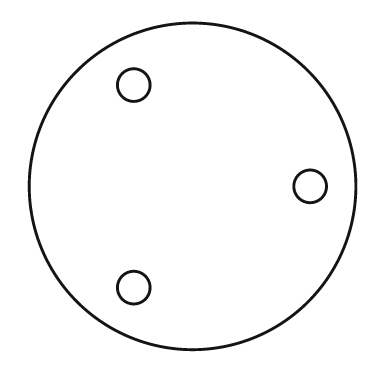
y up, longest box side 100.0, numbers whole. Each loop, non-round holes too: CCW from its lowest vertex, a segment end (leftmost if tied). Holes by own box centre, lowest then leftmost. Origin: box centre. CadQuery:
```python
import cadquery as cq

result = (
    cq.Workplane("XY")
    .moveTo(0.0, 0.0)
    .circle(50.0)
    .moveTo(-18.0, -31.0)
    .circle(5.0)
    .moveTo(36.0, 0.0)
    .circle(5.0)
    .moveTo(-18.0, 31.0)
    .circle(5.0)
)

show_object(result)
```